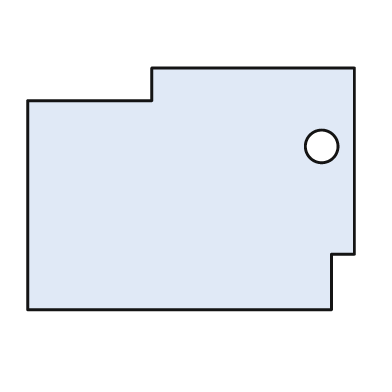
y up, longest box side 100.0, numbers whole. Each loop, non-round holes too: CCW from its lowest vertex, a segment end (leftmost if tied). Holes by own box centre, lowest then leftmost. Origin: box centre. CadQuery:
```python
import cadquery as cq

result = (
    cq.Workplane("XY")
    .moveTo(-50.0, -37.0)
    .lineTo(43.0, -37.0)
    .lineTo(43.0, -20.0)
    .lineTo(50.0, -20.0)
    .lineTo(50.0, 37.0)
    .lineTo(-12.0, 37.0)
    .lineTo(-12.0, 27.0)
    .lineTo(-50.0, 27.0)
    .close()
    .moveTo(40.0, 13.0)
    .circle(5.0)
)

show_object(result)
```